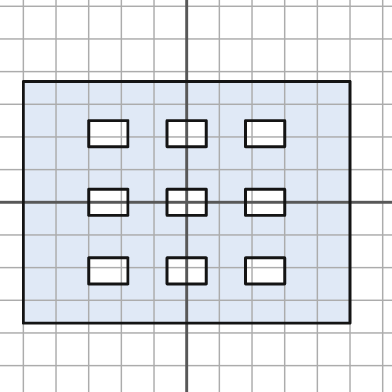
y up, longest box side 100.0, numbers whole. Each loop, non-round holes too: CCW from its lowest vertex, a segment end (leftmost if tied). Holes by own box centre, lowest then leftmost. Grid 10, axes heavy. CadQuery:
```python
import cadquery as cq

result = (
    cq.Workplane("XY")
    .moveTo(-50.0, -37.0)
    .lineTo(50.0, -37.0)
    .lineTo(50.0, 37.0)
    .lineTo(-50.0, 37.0)
    .close()
    .moveTo(-30.0, -25.0)
    .lineTo(-18.0, -25.0)
    .lineTo(-18.0, -17.0)
    .lineTo(-30.0, -17.0)
    .close()
    .moveTo(-6.0, -25.0)
    .lineTo(6.0, -25.0)
    .lineTo(6.0, -17.0)
    .lineTo(-6.0, -17.0)
    .close()
    .moveTo(18.0, -25.0)
    .lineTo(30.0, -25.0)
    .lineTo(30.0, -17.0)
    .lineTo(18.0, -17.0)
    .close()
    .moveTo(-30.0, -4.0)
    .lineTo(-18.0, -4.0)
    .lineTo(-18.0, 4.0)
    .lineTo(-30.0, 4.0)
    .close()
    .moveTo(-6.0, -4.0)
    .lineTo(6.0, -4.0)
    .lineTo(6.0, 4.0)
    .lineTo(-6.0, 4.0)
    .close()
    .moveTo(18.0, -4.0)
    .lineTo(30.0, -4.0)
    .lineTo(30.0, 4.0)
    .lineTo(18.0, 4.0)
    .close()
    .moveTo(-30.0, 17.0)
    .lineTo(-18.0, 17.0)
    .lineTo(-18.0, 25.0)
    .lineTo(-30.0, 25.0)
    .close()
    .moveTo(-6.0, 17.0)
    .lineTo(6.0, 17.0)
    .lineTo(6.0, 25.0)
    .lineTo(-6.0, 25.0)
    .close()
    .moveTo(18.0, 17.0)
    .lineTo(30.0, 17.0)
    .lineTo(30.0, 25.0)
    .lineTo(18.0, 25.0)
    .close()
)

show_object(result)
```